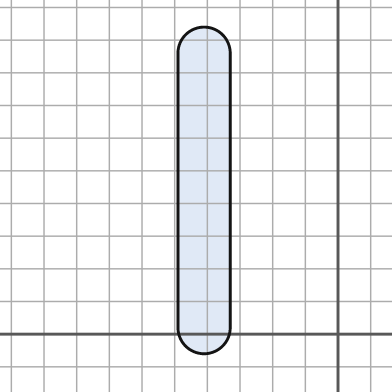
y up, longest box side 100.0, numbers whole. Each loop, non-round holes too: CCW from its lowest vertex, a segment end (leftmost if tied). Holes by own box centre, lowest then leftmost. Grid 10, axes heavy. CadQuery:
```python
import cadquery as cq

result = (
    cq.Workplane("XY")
    .moveTo(-49.0, 2.0)
    .threePointArc((-41.0, -6.0), (-33.0, 2.0))
    .lineTo(-33.0, 86.0)
    .threePointArc((-41.0, 94.0), (-49.0, 86.0))
    .close()
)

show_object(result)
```